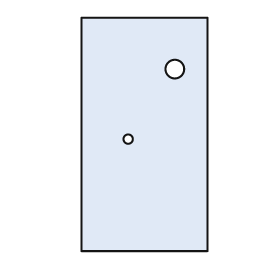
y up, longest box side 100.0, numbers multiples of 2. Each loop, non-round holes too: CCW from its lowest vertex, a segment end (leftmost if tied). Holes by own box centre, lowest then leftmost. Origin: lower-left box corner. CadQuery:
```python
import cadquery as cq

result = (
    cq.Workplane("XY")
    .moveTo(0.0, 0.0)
    .lineTo(54.0, 0.0)
    .lineTo(54.0, 100.0)
    .lineTo(0.0, 100.0)
    .close()
    .moveTo(20.0, 48.0)
    .circle(2.0)
    .moveTo(40.0, 78.0)
    .circle(4.0)
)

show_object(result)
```